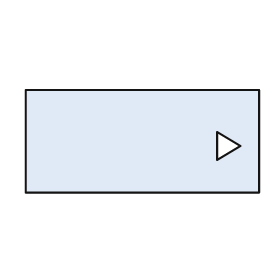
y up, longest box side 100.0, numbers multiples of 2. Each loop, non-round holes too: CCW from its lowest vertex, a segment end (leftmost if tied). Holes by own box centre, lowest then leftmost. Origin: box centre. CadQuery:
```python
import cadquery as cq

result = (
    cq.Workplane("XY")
    .moveTo(-50.0, -22.0)
    .lineTo(50.0, -22.0)
    .lineTo(50.0, 22.0)
    .lineTo(-50.0, 22.0)
    .close()
    .moveTo(32.0, -8.0)
    .lineTo(42.0, -2.0)
    .lineTo(32.0, 4.0)
    .close()
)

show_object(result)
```